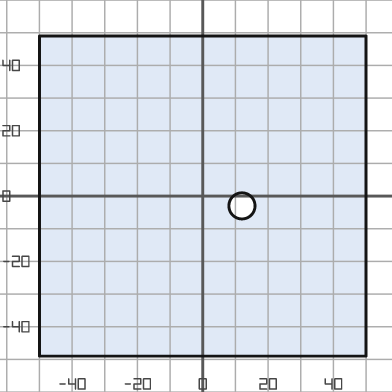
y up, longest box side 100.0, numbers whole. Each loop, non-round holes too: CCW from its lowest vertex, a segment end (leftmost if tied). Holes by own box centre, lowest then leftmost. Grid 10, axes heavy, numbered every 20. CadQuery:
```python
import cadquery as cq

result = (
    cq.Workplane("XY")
    .moveTo(-50.0, -49.0)
    .lineTo(50.0, -49.0)
    .lineTo(50.0, 49.0)
    .lineTo(-50.0, 49.0)
    .close()
    .moveTo(12.0, -3.0)
    .circle(4.0)
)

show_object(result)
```